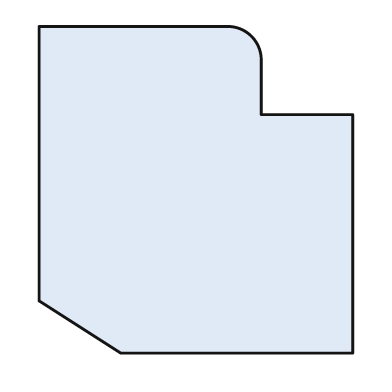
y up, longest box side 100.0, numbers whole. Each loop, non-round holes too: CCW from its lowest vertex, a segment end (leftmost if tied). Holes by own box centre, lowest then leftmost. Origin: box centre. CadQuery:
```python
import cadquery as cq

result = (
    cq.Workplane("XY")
    .moveTo(-23.0, -50.0)
    .lineTo(48.0, -50.0)
    .lineTo(48.0, 23.0)
    .lineTo(20.0, 23.0)
    .lineTo(20.0, 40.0)
    .threePointArc((17.0, 47.0), (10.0, 50.0))
    .lineTo(-48.0, 50.0)
    .lineTo(-48.0, -34.0)
    .close()
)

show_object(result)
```